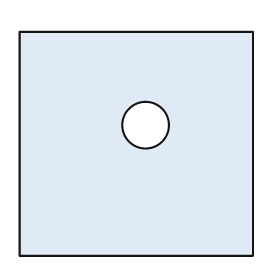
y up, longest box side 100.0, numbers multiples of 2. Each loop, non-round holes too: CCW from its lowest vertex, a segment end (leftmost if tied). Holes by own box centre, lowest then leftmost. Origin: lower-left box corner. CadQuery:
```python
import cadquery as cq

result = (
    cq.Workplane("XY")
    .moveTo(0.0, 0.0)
    .lineTo(100.0, 0.0)
    .lineTo(100.0, 96.0)
    .lineTo(0.0, 96.0)
    .close()
    .moveTo(54.0, 56.0)
    .circle(10.0)
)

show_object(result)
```